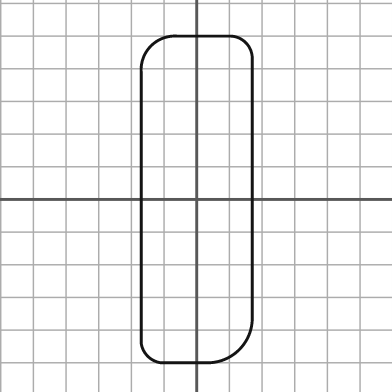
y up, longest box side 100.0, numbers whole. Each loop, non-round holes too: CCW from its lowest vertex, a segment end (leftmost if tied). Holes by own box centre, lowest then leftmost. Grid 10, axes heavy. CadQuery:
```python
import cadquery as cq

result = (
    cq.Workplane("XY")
    .moveTo(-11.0, -50.0)
    .lineTo(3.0, -50.0)
    .threePointArc((13.0, -46.0), (17.0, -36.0))
    .lineTo(17.0, 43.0)
    .threePointArc((15.0, 48.0), (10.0, 50.0))
    .lineTo(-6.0, 50.0)
    .threePointArc((-14.0, 47.0), (-17.0, 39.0))
    .lineTo(-17.0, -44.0)
    .threePointArc((-15.0, -48.0), (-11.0, -50.0))
    .close()
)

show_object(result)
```